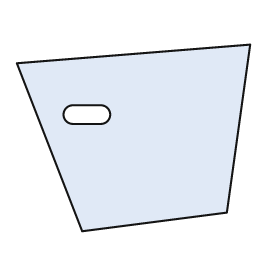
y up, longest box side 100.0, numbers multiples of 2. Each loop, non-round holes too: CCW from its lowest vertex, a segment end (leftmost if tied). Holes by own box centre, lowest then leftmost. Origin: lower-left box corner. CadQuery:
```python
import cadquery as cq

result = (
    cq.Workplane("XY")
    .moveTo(28.0, 0.0)
    .lineTo(90.0, 8.0)
    .lineTo(100.0, 80.0)
    .lineTo(0.0, 72.0)
    .close()
    .moveTo(24.0, 46.0)
    .lineTo(36.0, 46.0)
    .threePointArc((40.0, 50.0), (36.0, 54.0))
    .lineTo(24.0, 54.0)
    .threePointArc((20.0, 50.0), (24.0, 46.0))
    .close()
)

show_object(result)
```